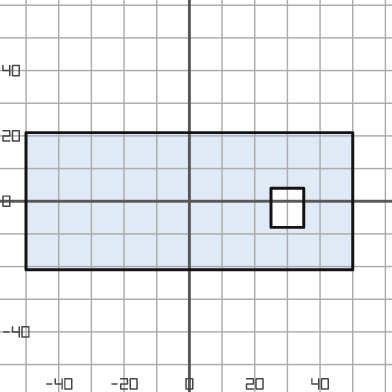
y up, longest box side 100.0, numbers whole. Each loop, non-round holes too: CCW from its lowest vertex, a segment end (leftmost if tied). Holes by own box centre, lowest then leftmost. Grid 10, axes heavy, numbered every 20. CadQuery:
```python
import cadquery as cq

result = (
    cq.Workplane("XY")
    .moveTo(-50.0, -21.0)
    .lineTo(50.0, -21.0)
    .lineTo(50.0, 21.0)
    .lineTo(-50.0, 21.0)
    .close()
    .moveTo(25.0, -8.0)
    .lineTo(35.0, -8.0)
    .lineTo(35.0, 4.0)
    .lineTo(25.0, 4.0)
    .close()
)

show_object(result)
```